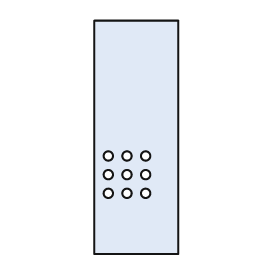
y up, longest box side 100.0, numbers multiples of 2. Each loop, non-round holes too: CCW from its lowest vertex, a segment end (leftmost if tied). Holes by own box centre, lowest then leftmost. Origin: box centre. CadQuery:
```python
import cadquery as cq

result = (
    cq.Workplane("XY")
    .moveTo(-18.0, -50.0)
    .lineTo(18.0, -50.0)
    .lineTo(18.0, 50.0)
    .lineTo(-18.0, 50.0)
    .close()
    .moveTo(-12.0, -24.0)
    .circle(2.0)
    .moveTo(-4.0, -24.0)
    .circle(2.0)
    .moveTo(4.0, -24.0)
    .circle(2.0)
    .moveTo(-12.0, -16.0)
    .circle(2.0)
    .moveTo(-4.0, -16.0)
    .circle(2.0)
    .moveTo(4.0, -16.0)
    .circle(2.0)
    .moveTo(-12.0, -8.0)
    .circle(2.0)
    .moveTo(-4.0, -8.0)
    .circle(2.0)
    .moveTo(4.0, -8.0)
    .circle(2.0)
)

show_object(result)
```